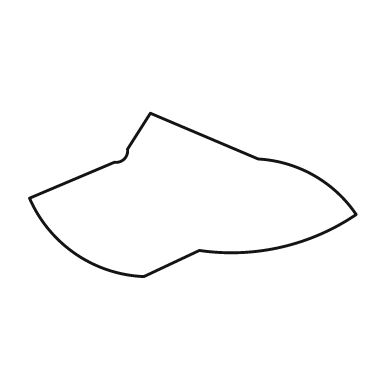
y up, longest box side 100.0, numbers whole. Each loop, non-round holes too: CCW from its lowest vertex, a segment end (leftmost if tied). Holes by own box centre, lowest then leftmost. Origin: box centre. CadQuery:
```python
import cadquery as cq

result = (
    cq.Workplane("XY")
    .moveTo(-15.0, -25.0)
    .lineTo(2.0, -17.0)
    .threePointArc((27.0, -16.0), (50.0, -6.0))
    .threePointArc((37.0, 6.0), (20.0, 11.0))
    .lineTo(-13.0, 25.0)
    .lineTo(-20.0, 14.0)
    .threePointArc((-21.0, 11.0), (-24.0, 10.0))
    .lineTo(-50.0, -1.0)
    .threePointArc((-36.0, -18.0), (-15.0, -25.0))
    .close()
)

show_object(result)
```